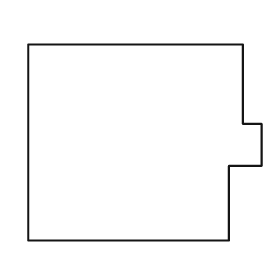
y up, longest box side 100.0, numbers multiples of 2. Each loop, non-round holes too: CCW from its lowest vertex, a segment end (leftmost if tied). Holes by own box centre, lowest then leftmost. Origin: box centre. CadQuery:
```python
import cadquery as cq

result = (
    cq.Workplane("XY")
    .moveTo(-50.0, -42.0)
    .lineTo(36.0, -42.0)
    .lineTo(36.0, -10.0)
    .lineTo(50.0, -10.0)
    .lineTo(50.0, 8.0)
    .lineTo(42.0, 8.0)
    .lineTo(42.0, 42.0)
    .lineTo(-50.0, 42.0)
    .close()
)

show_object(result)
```